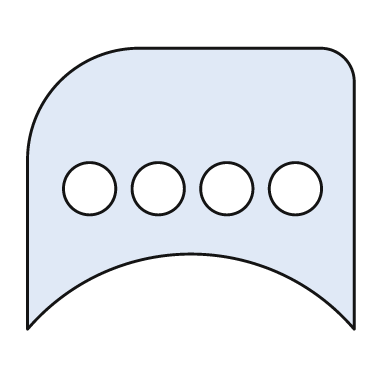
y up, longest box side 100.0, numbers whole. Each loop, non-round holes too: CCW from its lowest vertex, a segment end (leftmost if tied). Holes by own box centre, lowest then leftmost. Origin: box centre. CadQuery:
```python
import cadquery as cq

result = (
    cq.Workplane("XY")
    .moveTo(-50.0, -43.0)
    .threePointArc((0.0, -20.0), (50.0, -43.0))
    .lineTo(50.0, 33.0)
    .threePointArc((47.0, 40.0), (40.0, 43.0))
    .lineTo(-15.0, 43.0)
    .threePointArc((-40.0, 33.0), (-50.0, 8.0))
    .close()
    .moveTo(-31.0, 0.0)
    .circle(8.0)
    .moveTo(-10.0, 0.0)
    .circle(8.0)
    .moveTo(11.0, 0.0)
    .circle(8.0)
    .moveTo(32.0, 0.0)
    .circle(8.0)
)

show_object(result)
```